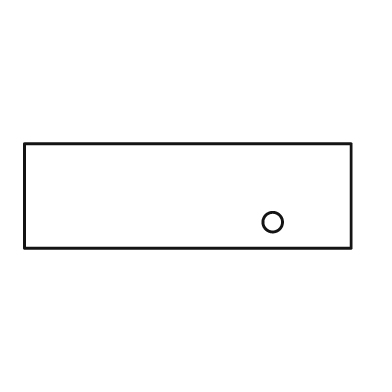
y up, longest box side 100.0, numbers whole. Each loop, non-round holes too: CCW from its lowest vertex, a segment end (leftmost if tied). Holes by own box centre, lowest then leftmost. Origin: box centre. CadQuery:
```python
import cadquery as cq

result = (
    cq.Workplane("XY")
    .moveTo(-50.0, -16.0)
    .lineTo(50.0, -16.0)
    .lineTo(50.0, 16.0)
    .lineTo(-50.0, 16.0)
    .close()
    .moveTo(26.0, -8.0)
    .circle(3.0)
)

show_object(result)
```